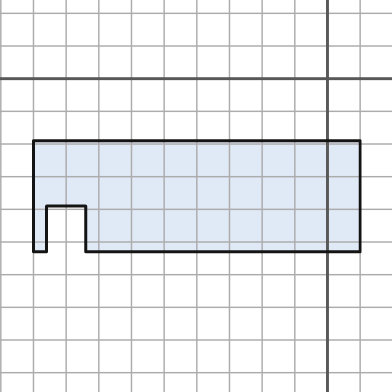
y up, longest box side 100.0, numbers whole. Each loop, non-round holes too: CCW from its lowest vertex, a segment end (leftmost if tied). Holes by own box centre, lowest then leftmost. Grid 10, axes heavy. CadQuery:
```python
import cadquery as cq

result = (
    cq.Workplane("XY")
    .moveTo(-90.0, -53.0)
    .lineTo(-86.0, -53.0)
    .lineTo(-86.0, -39.0)
    .lineTo(-74.0, -39.0)
    .lineTo(-74.0, -53.0)
    .lineTo(10.0, -53.0)
    .lineTo(10.0, -19.0)
    .lineTo(-90.0, -19.0)
    .close()
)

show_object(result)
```